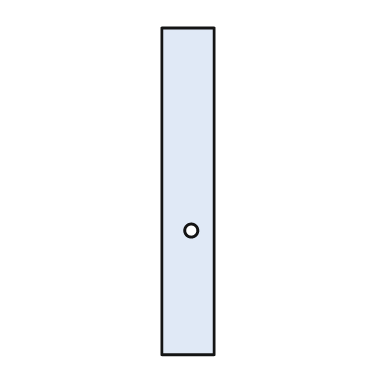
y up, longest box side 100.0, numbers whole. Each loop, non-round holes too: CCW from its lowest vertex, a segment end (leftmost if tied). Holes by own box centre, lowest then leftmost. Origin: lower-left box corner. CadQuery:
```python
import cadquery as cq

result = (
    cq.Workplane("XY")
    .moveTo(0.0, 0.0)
    .lineTo(16.0, 0.0)
    .lineTo(16.0, 100.0)
    .lineTo(0.0, 100.0)
    .close()
    .moveTo(9.0, 38.0)
    .circle(2.0)
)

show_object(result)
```